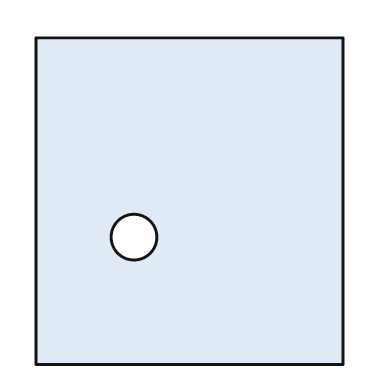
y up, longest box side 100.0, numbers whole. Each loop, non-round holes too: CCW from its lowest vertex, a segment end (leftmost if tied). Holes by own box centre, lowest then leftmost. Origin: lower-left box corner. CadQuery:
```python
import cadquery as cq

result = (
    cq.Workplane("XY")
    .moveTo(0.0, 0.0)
    .lineTo(94.0, 0.0)
    .lineTo(94.0, 100.0)
    .lineTo(0.0, 100.0)
    .close()
    .moveTo(30.0, 39.0)
    .circle(7.0)
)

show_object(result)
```